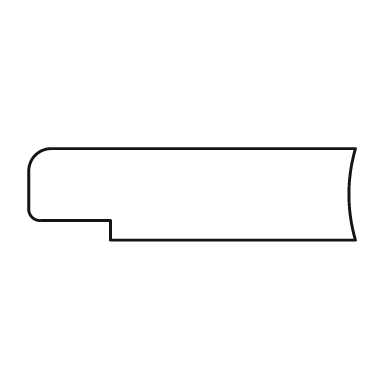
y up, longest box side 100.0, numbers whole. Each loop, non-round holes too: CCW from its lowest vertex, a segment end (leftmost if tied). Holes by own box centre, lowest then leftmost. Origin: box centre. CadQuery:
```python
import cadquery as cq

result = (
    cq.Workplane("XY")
    .moveTo(-25.0, -14.0)
    .lineTo(50.0, -14.0)
    .threePointArc((48.0, 0.0), (50.0, 14.0))
    .lineTo(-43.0, 14.0)
    .threePointArc((-48.0, 12.0), (-50.0, 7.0))
    .lineTo(-50.0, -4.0)
    .threePointArc((-49.0, -7.0), (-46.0, -8.0))
    .lineTo(-25.0, -8.0)
    .close()
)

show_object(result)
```